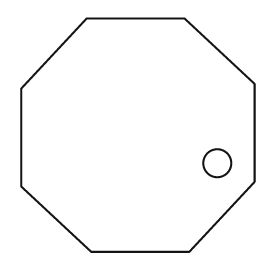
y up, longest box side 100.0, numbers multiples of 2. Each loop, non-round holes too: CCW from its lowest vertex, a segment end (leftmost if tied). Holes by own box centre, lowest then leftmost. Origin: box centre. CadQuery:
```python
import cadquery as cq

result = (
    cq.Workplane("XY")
    .moveTo(-20.0, -50.0)
    .lineTo(22.0, -50.0)
    .lineTo(50.0, -20.0)
    .lineTo(50.0, 22.0)
    .lineTo(20.0, 50.0)
    .lineTo(-22.0, 50.0)
    .lineTo(-50.0, 20.0)
    .lineTo(-50.0, -22.0)
    .close()
    .moveTo(34.0, -12.0)
    .circle(6.0)
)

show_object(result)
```